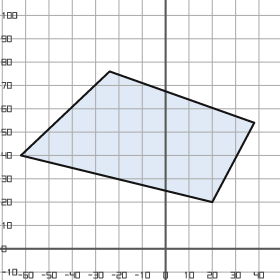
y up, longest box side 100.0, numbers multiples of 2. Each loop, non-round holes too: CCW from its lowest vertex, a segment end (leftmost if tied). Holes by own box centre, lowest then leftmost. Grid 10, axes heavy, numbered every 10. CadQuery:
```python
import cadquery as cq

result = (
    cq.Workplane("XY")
    .moveTo(20.0, 20.0)
    .lineTo(38.0, 54.0)
    .lineTo(-24.0, 76.0)
    .lineTo(-62.0, 40.0)
    .close()
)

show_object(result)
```